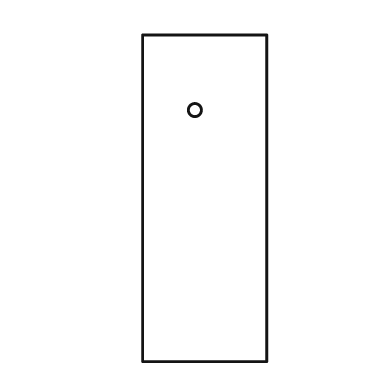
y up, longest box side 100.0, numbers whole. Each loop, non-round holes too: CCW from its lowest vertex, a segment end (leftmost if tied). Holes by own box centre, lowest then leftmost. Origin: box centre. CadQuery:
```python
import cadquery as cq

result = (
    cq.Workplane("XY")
    .moveTo(-19.0, -50.0)
    .lineTo(19.0, -50.0)
    .lineTo(19.0, 50.0)
    .lineTo(-19.0, 50.0)
    .close()
    .moveTo(-3.0, 27.0)
    .circle(2.0)
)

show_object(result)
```